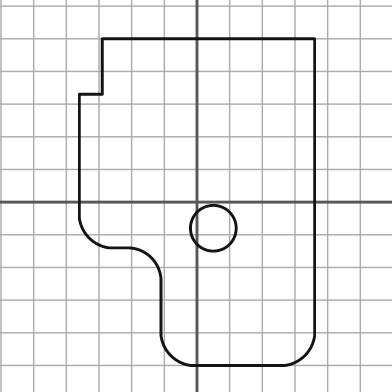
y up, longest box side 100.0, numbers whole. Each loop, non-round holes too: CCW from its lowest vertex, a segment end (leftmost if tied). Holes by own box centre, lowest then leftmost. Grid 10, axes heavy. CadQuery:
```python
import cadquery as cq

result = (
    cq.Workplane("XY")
    .moveTo(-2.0, -50.0)
    .lineTo(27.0, -50.0)
    .threePointArc((33.0, -47.0), (36.0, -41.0))
    .lineTo(36.0, 50.0)
    .lineTo(-29.0, 50.0)
    .lineTo(-29.0, 33.0)
    .lineTo(-36.0, 33.0)
    .lineTo(-36.0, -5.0)
    .threePointArc((-33.0, -11.0), (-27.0, -14.0))
    .lineTo(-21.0, -14.0)
    .threePointArc((-14.0, -17.0), (-11.0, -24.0))
    .lineTo(-11.0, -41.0)
    .threePointArc((-8.0, -47.0), (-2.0, -50.0))
    .close()
    .moveTo(5.0, -8.0)
    .circle(7.0)
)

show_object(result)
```